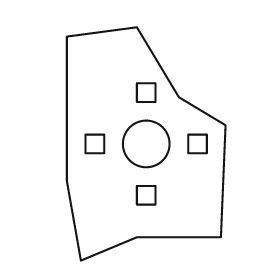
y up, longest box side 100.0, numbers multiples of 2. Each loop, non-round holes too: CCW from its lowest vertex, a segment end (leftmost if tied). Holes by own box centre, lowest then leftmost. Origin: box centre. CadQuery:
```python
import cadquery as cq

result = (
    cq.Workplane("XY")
    .moveTo(-28.0, -50.0)
    .lineTo(-4.0, -40.0)
    .lineTo(32.0, -40.0)
    .lineTo(34.0, 8.0)
    .lineTo(14.0, 20.0)
    .lineTo(-4.0, 50.0)
    .lineTo(-34.0, 46.0)
    .lineTo(-34.0, -16.0)
    .close()
    .moveTo(-4.0, -26.0)
    .lineTo(4.0, -26.0)
    .lineTo(4.0, -18.0)
    .lineTo(-4.0, -18.0)
    .close()
    .moveTo(-26.0, -4.0)
    .lineTo(-18.0, -4.0)
    .lineTo(-18.0, 4.0)
    .lineTo(-26.0, 4.0)
    .close()
    .moveTo(0.0, 0.0)
    .circle(10.0)
    .moveTo(18.0, -4.0)
    .lineTo(26.0, -4.0)
    .lineTo(26.0, 4.0)
    .lineTo(18.0, 4.0)
    .close()
    .moveTo(-4.0, 18.0)
    .lineTo(4.0, 18.0)
    .lineTo(4.0, 26.0)
    .lineTo(-4.0, 26.0)
    .close()
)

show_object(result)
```